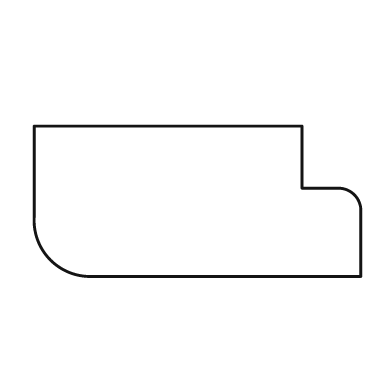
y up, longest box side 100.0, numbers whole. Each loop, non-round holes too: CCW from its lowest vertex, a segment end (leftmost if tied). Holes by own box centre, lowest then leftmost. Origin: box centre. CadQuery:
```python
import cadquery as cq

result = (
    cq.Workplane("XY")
    .moveTo(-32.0, -23.0)
    .lineTo(50.0, -23.0)
    .lineTo(50.0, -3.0)
    .threePointArc((48.0, 2.0), (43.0, 4.0))
    .lineTo(32.0, 4.0)
    .lineTo(32.0, 23.0)
    .lineTo(-50.0, 23.0)
    .lineTo(-50.0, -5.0)
    .threePointArc((-45.0, -18.0), (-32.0, -23.0))
    .close()
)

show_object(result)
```